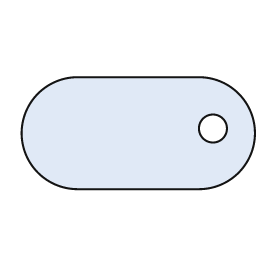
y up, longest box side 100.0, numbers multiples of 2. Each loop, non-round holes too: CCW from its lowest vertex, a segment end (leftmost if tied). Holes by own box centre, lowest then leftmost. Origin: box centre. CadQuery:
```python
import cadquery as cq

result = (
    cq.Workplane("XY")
    .moveTo(-26.0, -24.0)
    .lineTo(26.0, -24.0)
    .threePointArc((50.0, 0.0), (26.0, 24.0))
    .lineTo(-26.0, 24.0)
    .threePointArc((-50.0, 0.0), (-26.0, -24.0))
    .close()
    .moveTo(32.0, 2.0)
    .circle(6.0)
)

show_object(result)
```